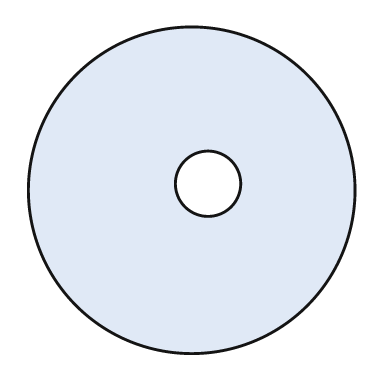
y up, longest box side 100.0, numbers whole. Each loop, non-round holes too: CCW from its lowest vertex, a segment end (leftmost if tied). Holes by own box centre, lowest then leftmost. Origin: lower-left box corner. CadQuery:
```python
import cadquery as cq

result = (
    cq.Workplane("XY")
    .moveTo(50.0, 50.0)
    .circle(50.0)
    .moveTo(55.0, 52.0)
    .circle(10.0)
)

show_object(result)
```